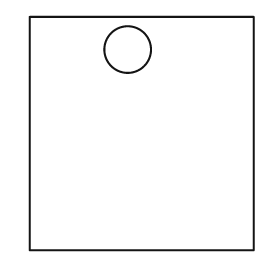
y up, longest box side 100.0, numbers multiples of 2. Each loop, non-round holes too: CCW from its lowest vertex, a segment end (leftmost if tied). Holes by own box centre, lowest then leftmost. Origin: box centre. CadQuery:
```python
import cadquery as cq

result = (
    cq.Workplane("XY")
    .moveTo(-48.0, -50.0)
    .lineTo(48.0, -50.0)
    .lineTo(48.0, 50.0)
    .lineTo(-48.0, 50.0)
    .close()
    .moveTo(-6.0, 36.0)
    .circle(10.0)
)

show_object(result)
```